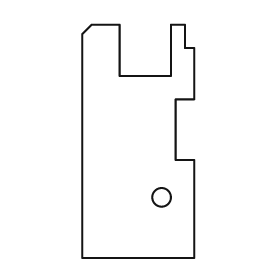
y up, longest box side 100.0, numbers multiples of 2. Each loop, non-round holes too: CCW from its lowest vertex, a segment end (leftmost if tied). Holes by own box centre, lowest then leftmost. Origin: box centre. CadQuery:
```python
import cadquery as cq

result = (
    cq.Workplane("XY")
    .moveTo(-24.0, -50.0)
    .lineTo(24.0, -50.0)
    .lineTo(24.0, -8.0)
    .lineTo(16.0, -8.0)
    .lineTo(16.0, 18.0)
    .lineTo(24.0, 18.0)
    .lineTo(24.0, 40.0)
    .lineTo(20.0, 40.0)
    .lineTo(20.0, 50.0)
    .lineTo(14.0, 50.0)
    .lineTo(14.0, 28.0)
    .lineTo(-8.0, 28.0)
    .lineTo(-8.0, 50.0)
    .lineTo(-20.0, 50.0)
    .lineTo(-24.0, 46.0)
    .close()
    .moveTo(10.0, -24.0)
    .circle(4.0)
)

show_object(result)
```